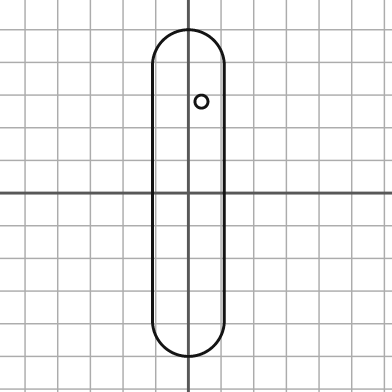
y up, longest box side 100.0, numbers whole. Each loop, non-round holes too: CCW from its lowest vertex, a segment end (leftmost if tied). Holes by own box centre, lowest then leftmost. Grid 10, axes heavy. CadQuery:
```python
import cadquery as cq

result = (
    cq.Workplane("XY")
    .moveTo(-11.0, -39.0)
    .threePointArc((0.0, -50.0), (11.0, -39.0))
    .lineTo(11.0, 39.0)
    .threePointArc((0.0, 50.0), (-11.0, 39.0))
    .close()
    .moveTo(4.0, 28.0)
    .circle(2.0)
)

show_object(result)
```